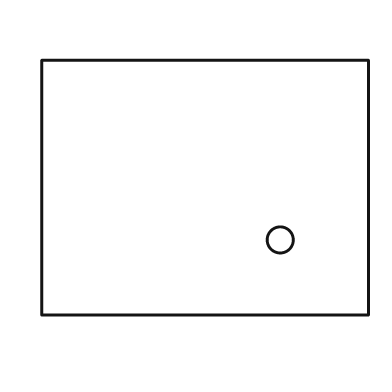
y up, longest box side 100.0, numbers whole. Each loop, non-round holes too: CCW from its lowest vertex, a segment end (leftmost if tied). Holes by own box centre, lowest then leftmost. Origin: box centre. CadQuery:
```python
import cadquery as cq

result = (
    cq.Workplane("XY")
    .moveTo(-50.0, -39.0)
    .lineTo(50.0, -39.0)
    .lineTo(50.0, 39.0)
    .lineTo(-50.0, 39.0)
    .close()
    .moveTo(23.0, -16.0)
    .circle(4.0)
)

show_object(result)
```